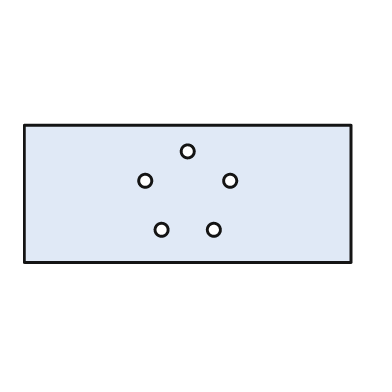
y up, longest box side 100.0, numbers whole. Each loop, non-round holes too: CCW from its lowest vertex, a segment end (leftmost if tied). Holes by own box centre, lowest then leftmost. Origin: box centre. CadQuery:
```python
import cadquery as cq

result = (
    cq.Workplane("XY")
    .moveTo(-50.0, -21.0)
    .lineTo(50.0, -21.0)
    .lineTo(50.0, 21.0)
    .lineTo(-50.0, 21.0)
    .close()
    .moveTo(-8.0, -11.0)
    .circle(2.0)
    .moveTo(8.0, -11.0)
    .circle(2.0)
    .moveTo(-13.0, 4.0)
    .circle(2.0)
    .moveTo(13.0, 4.0)
    .circle(2.0)
    .moveTo(0.0, 13.0)
    .circle(2.0)
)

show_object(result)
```